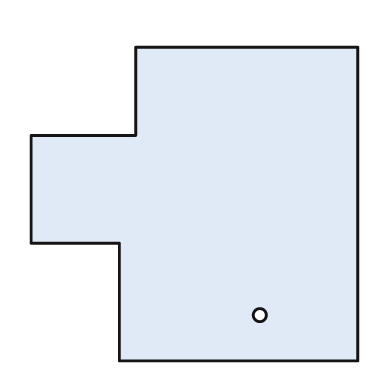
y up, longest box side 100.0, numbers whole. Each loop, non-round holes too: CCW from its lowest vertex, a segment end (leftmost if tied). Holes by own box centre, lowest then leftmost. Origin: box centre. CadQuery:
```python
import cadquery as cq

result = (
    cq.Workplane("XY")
    .moveTo(-23.0, -48.0)
    .lineTo(50.0, -48.0)
    .lineTo(50.0, 48.0)
    .lineTo(-18.0, 48.0)
    .lineTo(-18.0, 21.0)
    .lineTo(-50.0, 21.0)
    .lineTo(-50.0, -12.0)
    .lineTo(-23.0, -12.0)
    .close()
    .moveTo(20.0, -34.0)
    .circle(2.0)
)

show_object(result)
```